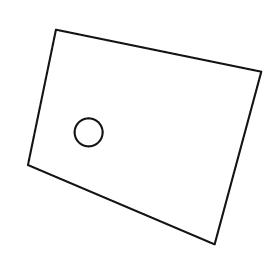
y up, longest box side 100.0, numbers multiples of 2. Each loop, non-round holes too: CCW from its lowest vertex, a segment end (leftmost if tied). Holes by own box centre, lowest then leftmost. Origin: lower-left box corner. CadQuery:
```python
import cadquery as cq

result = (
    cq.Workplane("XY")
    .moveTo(80.0, 0.0)
    .lineTo(100.0, 74.0)
    .lineTo(12.0, 92.0)
    .lineTo(0.0, 34.0)
    .close()
    .moveTo(26.0, 48.0)
    .circle(6.0)
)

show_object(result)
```